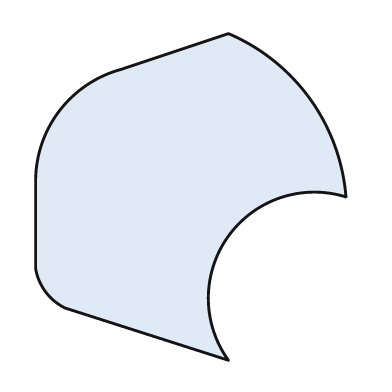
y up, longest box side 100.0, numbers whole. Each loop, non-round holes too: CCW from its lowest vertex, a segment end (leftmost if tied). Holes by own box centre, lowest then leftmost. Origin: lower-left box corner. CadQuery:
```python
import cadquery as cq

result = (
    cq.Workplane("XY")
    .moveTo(59.0, 0.0)
    .threePointArc((59.0, 38.0), (95.0, 50.0))
    .threePointArc((84.0, 80.0), (59.0, 100.0))
    .lineTo(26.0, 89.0)
    .threePointArc((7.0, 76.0), (0.0, 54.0))
    .lineTo(0.0, 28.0)
    .threePointArc((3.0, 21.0), (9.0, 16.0))
    .close()
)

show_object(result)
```